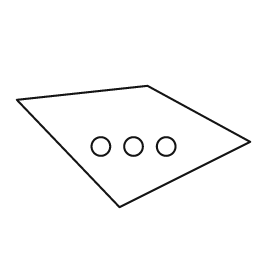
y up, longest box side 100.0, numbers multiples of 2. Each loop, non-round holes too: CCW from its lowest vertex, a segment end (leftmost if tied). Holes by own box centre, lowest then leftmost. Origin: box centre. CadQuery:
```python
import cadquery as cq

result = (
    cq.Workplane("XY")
    .moveTo(-6.0, -26.0)
    .lineTo(50.0, 2.0)
    .lineTo(6.0, 26.0)
    .lineTo(-50.0, 20.0)
    .close()
    .moveTo(-14.0, 0.0)
    .circle(4.0)
    .moveTo(0.0, 0.0)
    .circle(4.0)
    .moveTo(14.0, 0.0)
    .circle(4.0)
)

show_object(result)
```